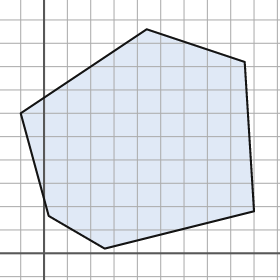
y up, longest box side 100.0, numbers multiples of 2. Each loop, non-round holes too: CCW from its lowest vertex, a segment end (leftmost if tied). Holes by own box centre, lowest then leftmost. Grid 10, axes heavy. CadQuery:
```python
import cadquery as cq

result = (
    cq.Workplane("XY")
    .moveTo(26.0, 2.0)
    .lineTo(90.0, 18.0)
    .lineTo(86.0, 82.0)
    .lineTo(44.0, 96.0)
    .lineTo(-10.0, 60.0)
    .lineTo(2.0, 16.0)
    .close()
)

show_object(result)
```